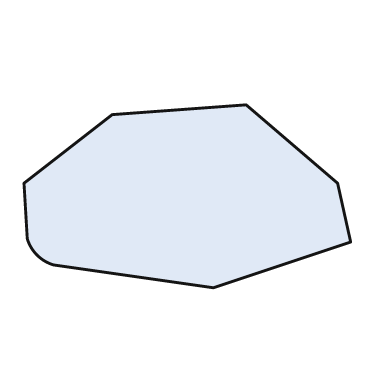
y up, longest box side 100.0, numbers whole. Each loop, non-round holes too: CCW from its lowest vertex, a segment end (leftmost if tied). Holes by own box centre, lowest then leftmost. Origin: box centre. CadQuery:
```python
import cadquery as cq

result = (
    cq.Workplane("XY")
    .moveTo(8.0, -28.0)
    .lineTo(50.0, -14.0)
    .lineTo(46.0, 4.0)
    .lineTo(18.0, 28.0)
    .lineTo(-23.0, 25.0)
    .lineTo(-50.0, 4.0)
    .lineTo(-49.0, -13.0)
    .threePointArc((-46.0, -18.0), (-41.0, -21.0))
    .close()
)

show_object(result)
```